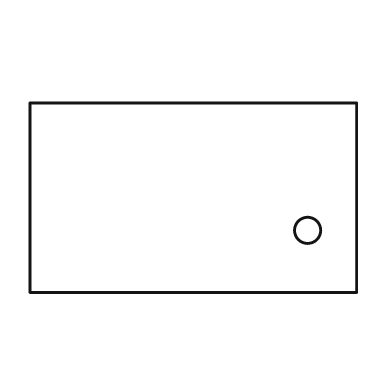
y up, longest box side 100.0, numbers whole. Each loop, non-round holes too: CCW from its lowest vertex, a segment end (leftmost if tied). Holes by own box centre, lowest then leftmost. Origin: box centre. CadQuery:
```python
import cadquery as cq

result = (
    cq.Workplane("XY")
    .moveTo(-50.0, -29.0)
    .lineTo(50.0, -29.0)
    .lineTo(50.0, 29.0)
    .lineTo(-50.0, 29.0)
    .close()
    .moveTo(35.0, -10.0)
    .circle(4.0)
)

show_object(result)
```